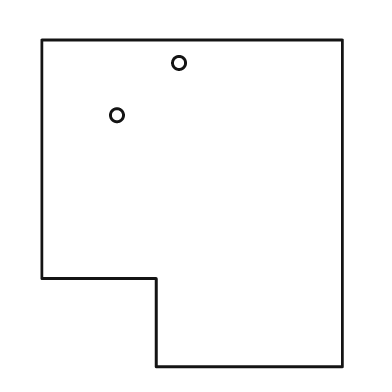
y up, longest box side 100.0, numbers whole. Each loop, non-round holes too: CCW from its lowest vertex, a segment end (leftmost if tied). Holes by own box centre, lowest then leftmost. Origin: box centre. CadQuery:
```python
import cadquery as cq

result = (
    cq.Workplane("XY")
    .moveTo(-11.0, -50.0)
    .lineTo(46.0, -50.0)
    .lineTo(46.0, 50.0)
    .lineTo(-46.0, 50.0)
    .lineTo(-46.0, -23.0)
    .lineTo(-11.0, -23.0)
    .close()
    .moveTo(-23.0, 27.0)
    .circle(2.0)
    .moveTo(-4.0, 43.0)
    .circle(2.0)
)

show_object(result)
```